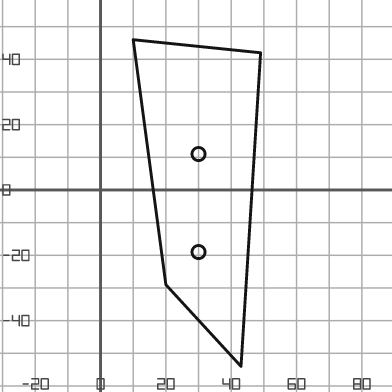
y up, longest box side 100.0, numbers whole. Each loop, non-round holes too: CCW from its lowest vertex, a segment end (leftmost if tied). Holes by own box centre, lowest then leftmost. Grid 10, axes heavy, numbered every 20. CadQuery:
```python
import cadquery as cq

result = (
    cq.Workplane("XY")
    .moveTo(43.0, -54.0)
    .lineTo(49.0, 42.0)
    .lineTo(10.0, 46.0)
    .lineTo(20.0, -29.0)
    .close()
    .moveTo(30.0, -19.0)
    .circle(2.0)
    .moveTo(30.0, 11.0)
    .circle(2.0)
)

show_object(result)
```